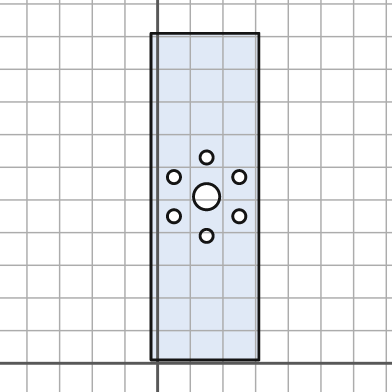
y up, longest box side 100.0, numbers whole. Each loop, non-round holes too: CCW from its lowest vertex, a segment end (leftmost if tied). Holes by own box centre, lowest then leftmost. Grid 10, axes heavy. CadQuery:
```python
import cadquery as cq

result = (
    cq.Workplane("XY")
    .moveTo(-2.0, 1.0)
    .lineTo(31.0, 1.0)
    .lineTo(31.0, 101.0)
    .lineTo(-2.0, 101.0)
    .close()
    .moveTo(15.0, 39.0)
    .circle(2.0)
    .moveTo(5.0, 45.0)
    .circle(2.0)
    .moveTo(25.0, 45.0)
    .circle(2.0)
    .moveTo(15.0, 51.0)
    .circle(4.0)
    .moveTo(5.0, 57.0)
    .circle(2.0)
    .moveTo(25.0, 57.0)
    .circle(2.0)
    .moveTo(15.0, 63.0)
    .circle(2.0)
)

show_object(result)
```